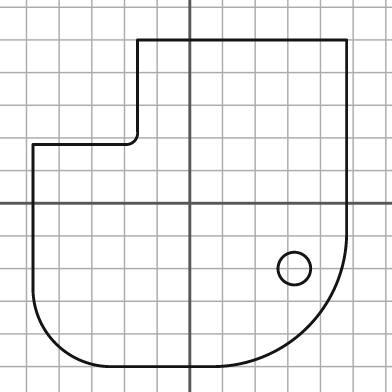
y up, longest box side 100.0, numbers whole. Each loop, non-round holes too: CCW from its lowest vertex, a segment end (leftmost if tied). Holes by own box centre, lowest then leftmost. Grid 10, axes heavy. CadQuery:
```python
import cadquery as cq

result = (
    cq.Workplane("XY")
    .moveTo(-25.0, -50.0)
    .lineTo(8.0, -50.0)
    .threePointArc((36.0, -38.0), (48.0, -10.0))
    .lineTo(48.0, 50.0)
    .lineTo(-16.0, 50.0)
    .lineTo(-16.0, 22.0)
    .threePointArc((-17.0, 19.0), (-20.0, 18.0))
    .lineTo(-48.0, 18.0)
    .lineTo(-48.0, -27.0)
    .threePointArc((-41.0, -43.0), (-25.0, -50.0))
    .close()
    .moveTo(32.0, -20.0)
    .circle(5.0)
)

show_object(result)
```